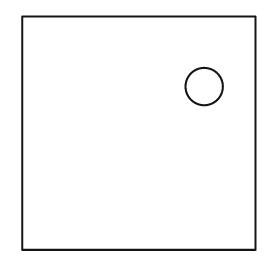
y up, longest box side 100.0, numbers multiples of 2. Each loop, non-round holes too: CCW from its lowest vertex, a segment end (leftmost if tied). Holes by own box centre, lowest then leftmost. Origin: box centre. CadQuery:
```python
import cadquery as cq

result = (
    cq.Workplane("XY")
    .moveTo(-50.0, -50.0)
    .lineTo(50.0, -50.0)
    .lineTo(50.0, 50.0)
    .lineTo(-50.0, 50.0)
    .close()
    .moveTo(28.0, 20.0)
    .circle(8.0)
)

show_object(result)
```